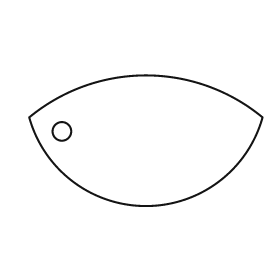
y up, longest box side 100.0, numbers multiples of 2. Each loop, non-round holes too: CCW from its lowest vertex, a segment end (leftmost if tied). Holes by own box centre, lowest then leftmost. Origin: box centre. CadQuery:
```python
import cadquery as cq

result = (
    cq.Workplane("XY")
    .moveTo(-50.0, 10.0)
    .threePointArc((0.0, -28.0), (50.0, 10.0))
    .threePointArc((0.0, 28.0), (-50.0, 10.0))
    .close()
    .moveTo(-36.0, 4.0)
    .circle(4.0)
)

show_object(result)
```